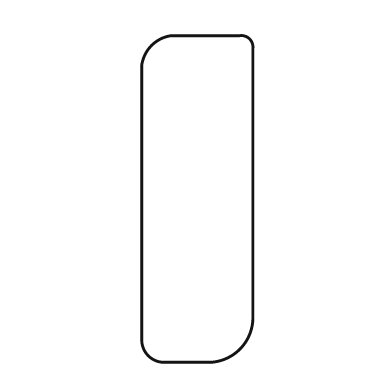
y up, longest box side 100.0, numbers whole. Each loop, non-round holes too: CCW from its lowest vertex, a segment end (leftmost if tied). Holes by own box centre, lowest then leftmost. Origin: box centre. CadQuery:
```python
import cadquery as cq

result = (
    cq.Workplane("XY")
    .moveTo(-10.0, -50.0)
    .lineTo(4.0, -50.0)
    .threePointArc((13.0, -46.0), (17.0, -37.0))
    .lineTo(17.0, 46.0)
    .threePointArc((16.0, 49.0), (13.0, 50.0))
    .lineTo(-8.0, 50.0)
    .threePointArc((-14.0, 47.0), (-17.0, 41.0))
    .lineTo(-17.0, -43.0)
    .threePointArc((-15.0, -48.0), (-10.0, -50.0))
    .close()
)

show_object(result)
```